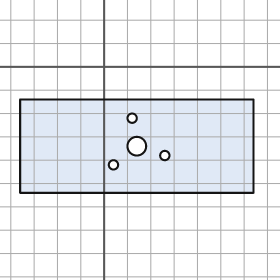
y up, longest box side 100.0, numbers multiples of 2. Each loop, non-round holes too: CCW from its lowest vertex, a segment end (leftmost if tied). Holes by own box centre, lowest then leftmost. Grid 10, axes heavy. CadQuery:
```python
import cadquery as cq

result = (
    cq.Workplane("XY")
    .moveTo(-36.0, -54.0)
    .lineTo(64.0, -54.0)
    .lineTo(64.0, -14.0)
    .lineTo(-36.0, -14.0)
    .close()
    .moveTo(4.0, -42.0)
    .circle(2.0)
    .moveTo(26.0, -38.0)
    .circle(2.0)
    .moveTo(14.0, -34.0)
    .circle(4.0)
    .moveTo(12.0, -22.0)
    .circle(2.0)
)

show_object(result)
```